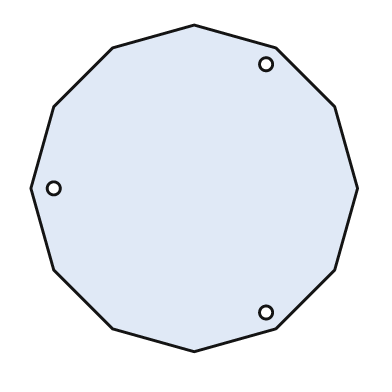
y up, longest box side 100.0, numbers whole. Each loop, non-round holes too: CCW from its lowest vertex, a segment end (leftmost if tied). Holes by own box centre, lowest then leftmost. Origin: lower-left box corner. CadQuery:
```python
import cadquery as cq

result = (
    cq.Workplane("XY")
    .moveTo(50.0, 0.0)
    .lineTo(75.0, 7.0)
    .lineTo(93.0, 25.0)
    .lineTo(100.0, 50.0)
    .lineTo(93.0, 75.0)
    .lineTo(75.0, 93.0)
    .lineTo(50.0, 100.0)
    .lineTo(25.0, 93.0)
    .lineTo(7.0, 75.0)
    .lineTo(0.0, 50.0)
    .lineTo(7.0, 25.0)
    .lineTo(25.0, 7.0)
    .close()
    .moveTo(72.0, 12.0)
    .circle(2.0)
    .moveTo(7.0, 50.0)
    .circle(2.0)
    .moveTo(72.0, 88.0)
    .circle(2.0)
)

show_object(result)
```